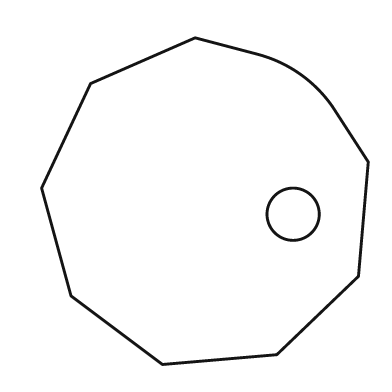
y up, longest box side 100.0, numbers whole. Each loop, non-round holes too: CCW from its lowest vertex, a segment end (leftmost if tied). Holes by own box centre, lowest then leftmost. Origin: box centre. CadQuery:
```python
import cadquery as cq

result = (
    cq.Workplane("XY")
    .moveTo(-13.0, -50.0)
    .lineTo(22.0, -47.0)
    .lineTo(47.0, -23.0)
    .lineTo(50.0, 12.0)
    .lineTo(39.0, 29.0)
    .threePointArc((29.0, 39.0), (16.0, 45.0))
    .lineTo(-3.0, 50.0)
    .lineTo(-35.0, 36.0)
    .lineTo(-50.0, 4.0)
    .lineTo(-41.0, -29.0)
    .close()
    .moveTo(27.0, -4.0)
    .circle(8.0)
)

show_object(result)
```